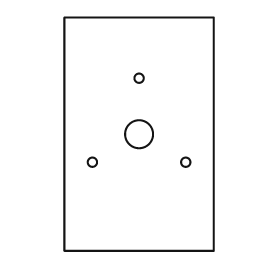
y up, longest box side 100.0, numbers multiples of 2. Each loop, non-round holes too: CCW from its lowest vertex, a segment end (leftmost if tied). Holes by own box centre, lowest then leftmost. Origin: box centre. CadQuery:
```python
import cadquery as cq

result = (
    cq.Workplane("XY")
    .moveTo(-32.0, -50.0)
    .lineTo(32.0, -50.0)
    .lineTo(32.0, 50.0)
    .lineTo(-32.0, 50.0)
    .close()
    .moveTo(-20.0, -12.0)
    .circle(2.0)
    .moveTo(20.0, -12.0)
    .circle(2.0)
    .moveTo(0.0, 0.0)
    .circle(6.0)
    .moveTo(0.0, 24.0)
    .circle(2.0)
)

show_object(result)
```